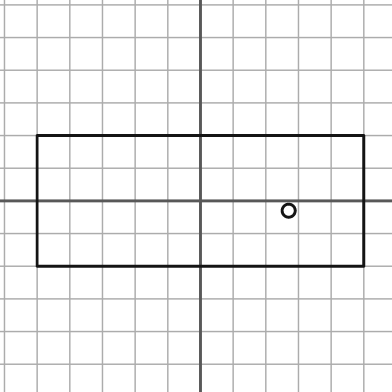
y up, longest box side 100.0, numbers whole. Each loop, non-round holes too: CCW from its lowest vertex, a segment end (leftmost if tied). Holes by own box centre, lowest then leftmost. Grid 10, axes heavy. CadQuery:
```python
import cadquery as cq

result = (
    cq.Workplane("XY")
    .moveTo(-50.0, -20.0)
    .lineTo(50.0, -20.0)
    .lineTo(50.0, 20.0)
    .lineTo(-50.0, 20.0)
    .close()
    .moveTo(27.0, -3.0)
    .circle(2.0)
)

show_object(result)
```